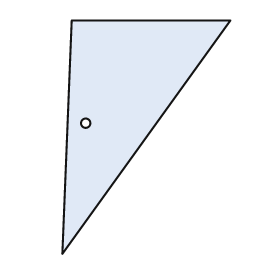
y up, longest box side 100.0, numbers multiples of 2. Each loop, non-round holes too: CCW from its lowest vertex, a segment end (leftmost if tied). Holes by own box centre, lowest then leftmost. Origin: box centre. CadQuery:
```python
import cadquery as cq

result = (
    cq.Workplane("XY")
    .moveTo(-36.0, -50.0)
    .lineTo(36.0, 50.0)
    .lineTo(-32.0, 50.0)
    .close()
    .moveTo(-26.0, 6.0)
    .circle(2.0)
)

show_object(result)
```